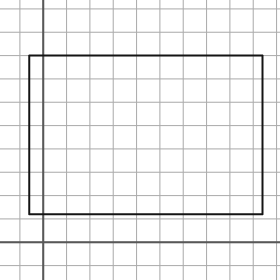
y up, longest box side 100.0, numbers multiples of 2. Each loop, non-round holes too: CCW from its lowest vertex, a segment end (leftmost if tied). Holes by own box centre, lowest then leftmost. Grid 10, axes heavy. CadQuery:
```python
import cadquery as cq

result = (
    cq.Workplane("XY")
    .moveTo(-6.0, 12.0)
    .lineTo(94.0, 12.0)
    .lineTo(94.0, 80.0)
    .lineTo(-6.0, 80.0)
    .close()
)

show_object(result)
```